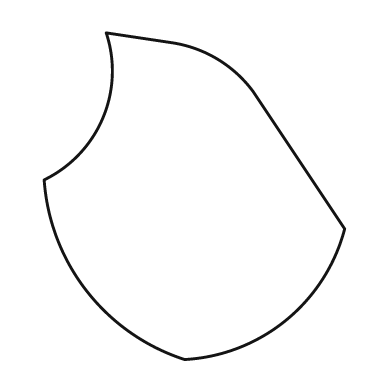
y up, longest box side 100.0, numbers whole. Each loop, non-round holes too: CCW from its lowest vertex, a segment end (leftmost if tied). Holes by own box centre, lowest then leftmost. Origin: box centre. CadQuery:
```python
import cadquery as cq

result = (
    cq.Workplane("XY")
    .moveTo(-3.0, -50.0)
    .threePointArc((28.0, -38.0), (46.0, -10.0))
    .lineTo(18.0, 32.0)
    .threePointArc((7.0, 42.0), (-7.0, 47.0))
    .lineTo(-27.0, 50.0)
    .threePointArc((-28.0, 24.0), (-46.0, 5.0))
    .threePointArc((-33.0, -29.0), (-3.0, -50.0))
    .close()
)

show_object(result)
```